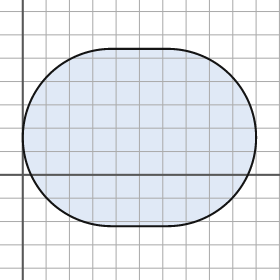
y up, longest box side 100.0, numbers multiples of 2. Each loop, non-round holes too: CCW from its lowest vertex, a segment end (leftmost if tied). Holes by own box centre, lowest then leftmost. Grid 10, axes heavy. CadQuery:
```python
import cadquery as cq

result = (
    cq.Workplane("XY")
    .moveTo(38.0, -22.0)
    .lineTo(62.0, -22.0)
    .threePointArc((100.0, 16.0), (62.0, 54.0))
    .lineTo(38.0, 54.0)
    .threePointArc((0.0, 16.0), (38.0, -22.0))
    .close()
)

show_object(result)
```